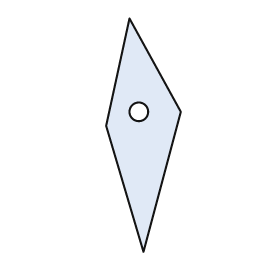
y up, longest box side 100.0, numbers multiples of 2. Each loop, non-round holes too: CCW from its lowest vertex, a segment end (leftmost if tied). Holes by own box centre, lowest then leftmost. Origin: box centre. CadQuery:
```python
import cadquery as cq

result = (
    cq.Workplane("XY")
    .moveTo(0.0, -50.0)
    .lineTo(16.0, 10.0)
    .lineTo(-6.0, 50.0)
    .lineTo(-16.0, 4.0)
    .close()
    .moveTo(-2.0, 10.0)
    .circle(4.0)
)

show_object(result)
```